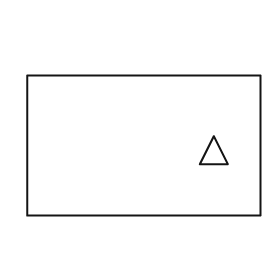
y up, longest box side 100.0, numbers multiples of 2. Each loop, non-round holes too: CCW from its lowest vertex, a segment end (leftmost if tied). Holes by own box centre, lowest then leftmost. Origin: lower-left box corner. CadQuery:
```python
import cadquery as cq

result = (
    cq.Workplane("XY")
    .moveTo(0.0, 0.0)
    .lineTo(100.0, 0.0)
    .lineTo(100.0, 60.0)
    .lineTo(0.0, 60.0)
    .close()
    .moveTo(74.0, 22.0)
    .lineTo(86.0, 22.0)
    .lineTo(80.0, 34.0)
    .close()
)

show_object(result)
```